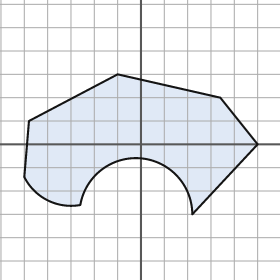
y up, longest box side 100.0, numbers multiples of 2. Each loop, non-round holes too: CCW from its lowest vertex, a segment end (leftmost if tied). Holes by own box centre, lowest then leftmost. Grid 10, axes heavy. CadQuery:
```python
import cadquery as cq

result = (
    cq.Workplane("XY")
    .moveTo(22.0, -30.0)
    .lineTo(50.0, 0.0)
    .lineTo(34.0, 20.0)
    .lineTo(-10.0, 30.0)
    .lineTo(-48.0, 10.0)
    .lineTo(-50.0, -14.0)
    .threePointArc((-40.0, -24.0), (-26.0, -26.0))
    .threePointArc((0.0, -6.0), (22.0, -30.0))
    .close()
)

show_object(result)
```